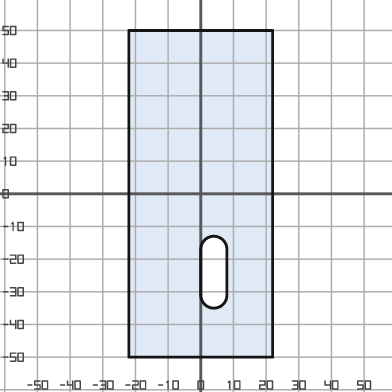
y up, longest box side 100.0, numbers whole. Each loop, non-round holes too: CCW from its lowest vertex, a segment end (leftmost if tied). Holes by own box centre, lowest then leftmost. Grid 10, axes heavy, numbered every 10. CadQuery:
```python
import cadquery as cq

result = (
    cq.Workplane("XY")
    .moveTo(-22.0, -50.0)
    .lineTo(22.0, -50.0)
    .lineTo(22.0, 50.0)
    .lineTo(-22.0, 50.0)
    .close()
    .moveTo(0.0, -31.0)
    .threePointArc((4.0, -35.0), (8.0, -31.0))
    .lineTo(8.0, -17.0)
    .threePointArc((4.0, -13.0), (0.0, -17.0))
    .close()
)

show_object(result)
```